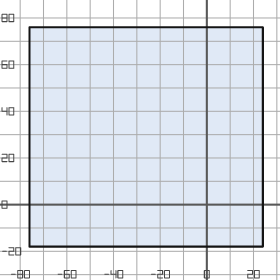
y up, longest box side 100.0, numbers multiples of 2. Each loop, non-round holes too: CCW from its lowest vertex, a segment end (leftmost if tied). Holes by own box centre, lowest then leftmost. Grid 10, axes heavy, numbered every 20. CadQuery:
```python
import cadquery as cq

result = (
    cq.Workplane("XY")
    .moveTo(-76.0, -18.0)
    .lineTo(24.0, -18.0)
    .lineTo(24.0, 76.0)
    .lineTo(-76.0, 76.0)
    .close()
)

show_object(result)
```